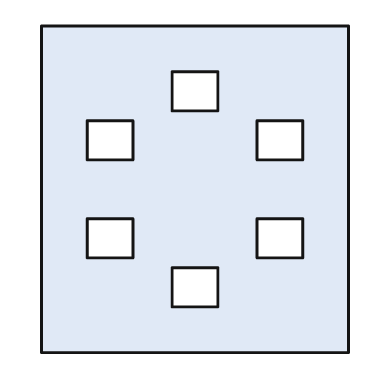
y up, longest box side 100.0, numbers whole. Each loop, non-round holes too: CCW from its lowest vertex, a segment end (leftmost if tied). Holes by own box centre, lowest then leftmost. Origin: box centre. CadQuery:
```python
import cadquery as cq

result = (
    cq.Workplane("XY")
    .moveTo(-47.0, -50.0)
    .lineTo(47.0, -50.0)
    .lineTo(47.0, 50.0)
    .lineTo(-47.0, 50.0)
    .close()
    .moveTo(-7.0, -36.0)
    .lineTo(7.0, -36.0)
    .lineTo(7.0, -24.0)
    .lineTo(-7.0, -24.0)
    .close()
    .moveTo(-33.0, -21.0)
    .lineTo(-19.0, -21.0)
    .lineTo(-19.0, -9.0)
    .lineTo(-33.0, -9.0)
    .close()
    .moveTo(19.0, -21.0)
    .lineTo(33.0, -21.0)
    .lineTo(33.0, -9.0)
    .lineTo(19.0, -9.0)
    .close()
    .moveTo(-33.0, 9.0)
    .lineTo(-19.0, 9.0)
    .lineTo(-19.0, 21.0)
    .lineTo(-33.0, 21.0)
    .close()
    .moveTo(19.0, 9.0)
    .lineTo(33.0, 9.0)
    .lineTo(33.0, 21.0)
    .lineTo(19.0, 21.0)
    .close()
    .moveTo(-7.0, 24.0)
    .lineTo(7.0, 24.0)
    .lineTo(7.0, 36.0)
    .lineTo(-7.0, 36.0)
    .close()
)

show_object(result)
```